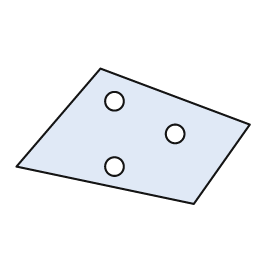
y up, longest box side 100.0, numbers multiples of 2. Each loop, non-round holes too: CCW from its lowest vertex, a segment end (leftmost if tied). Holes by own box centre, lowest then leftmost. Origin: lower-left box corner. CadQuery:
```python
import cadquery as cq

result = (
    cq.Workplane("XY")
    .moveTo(76.0, 0.0)
    .lineTo(100.0, 34.0)
    .lineTo(36.0, 58.0)
    .lineTo(0.0, 16.0)
    .close()
    .moveTo(42.0, 16.0)
    .circle(4.0)
    .moveTo(68.0, 30.0)
    .circle(4.0)
    .moveTo(42.0, 44.0)
    .circle(4.0)
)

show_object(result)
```